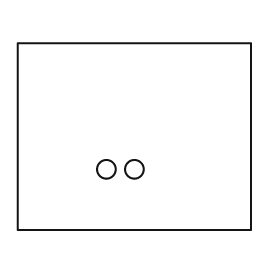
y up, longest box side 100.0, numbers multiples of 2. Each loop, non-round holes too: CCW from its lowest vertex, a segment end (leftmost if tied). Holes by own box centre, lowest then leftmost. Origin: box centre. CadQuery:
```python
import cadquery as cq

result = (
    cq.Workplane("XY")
    .moveTo(-50.0, -40.0)
    .lineTo(50.0, -40.0)
    .lineTo(50.0, 40.0)
    .lineTo(-50.0, 40.0)
    .close()
    .moveTo(-12.0, -14.0)
    .circle(4.0)
    .moveTo(0.0, -14.0)
    .circle(4.0)
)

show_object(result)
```